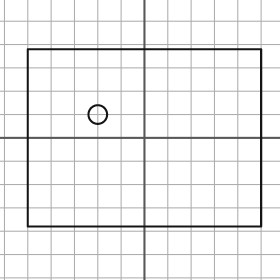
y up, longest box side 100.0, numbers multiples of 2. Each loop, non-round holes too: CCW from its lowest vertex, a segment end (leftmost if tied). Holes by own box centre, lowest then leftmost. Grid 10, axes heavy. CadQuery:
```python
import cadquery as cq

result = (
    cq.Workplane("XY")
    .moveTo(-50.0, -38.0)
    .lineTo(50.0, -38.0)
    .lineTo(50.0, 38.0)
    .lineTo(-50.0, 38.0)
    .close()
    .moveTo(-20.0, 10.0)
    .circle(4.0)
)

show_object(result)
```